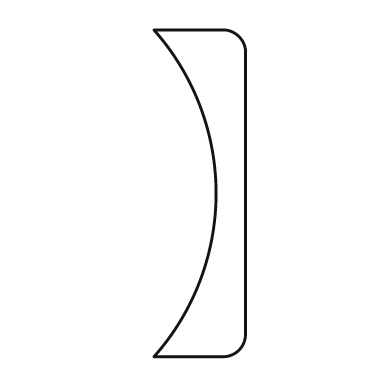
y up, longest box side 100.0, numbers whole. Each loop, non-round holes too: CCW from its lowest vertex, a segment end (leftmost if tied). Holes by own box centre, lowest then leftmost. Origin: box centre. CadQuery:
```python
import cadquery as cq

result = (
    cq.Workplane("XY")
    .moveTo(-14.0, -50.0)
    .lineTo(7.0, -50.0)
    .threePointArc((12.0, -48.0), (14.0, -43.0))
    .lineTo(14.0, 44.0)
    .threePointArc((12.0, 48.0), (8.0, 50.0))
    .lineTo(-14.0, 50.0)
    .threePointArc((5.0, 0.0), (-14.0, -50.0))
    .close()
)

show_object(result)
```